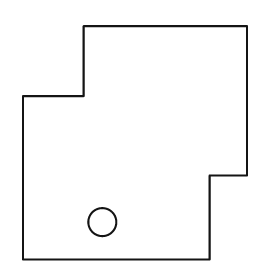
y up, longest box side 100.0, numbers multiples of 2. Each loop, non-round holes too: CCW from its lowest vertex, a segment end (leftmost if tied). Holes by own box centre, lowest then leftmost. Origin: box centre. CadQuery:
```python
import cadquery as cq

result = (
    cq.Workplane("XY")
    .moveTo(-48.0, -50.0)
    .lineTo(32.0, -50.0)
    .lineTo(32.0, -14.0)
    .lineTo(48.0, -14.0)
    .lineTo(48.0, 50.0)
    .lineTo(-22.0, 50.0)
    .lineTo(-22.0, 20.0)
    .lineTo(-48.0, 20.0)
    .close()
    .moveTo(-14.0, -34.0)
    .circle(6.0)
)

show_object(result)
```